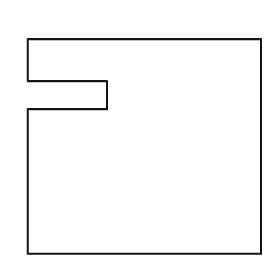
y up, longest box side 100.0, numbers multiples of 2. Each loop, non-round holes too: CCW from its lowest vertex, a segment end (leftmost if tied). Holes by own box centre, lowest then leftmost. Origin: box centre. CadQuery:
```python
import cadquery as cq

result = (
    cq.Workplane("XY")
    .moveTo(-50.0, -46.0)
    .lineTo(50.0, -46.0)
    .lineTo(50.0, 46.0)
    .lineTo(-50.0, 46.0)
    .lineTo(-50.0, 28.0)
    .lineTo(-16.0, 28.0)
    .lineTo(-16.0, 16.0)
    .lineTo(-50.0, 16.0)
    .close()
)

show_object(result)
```